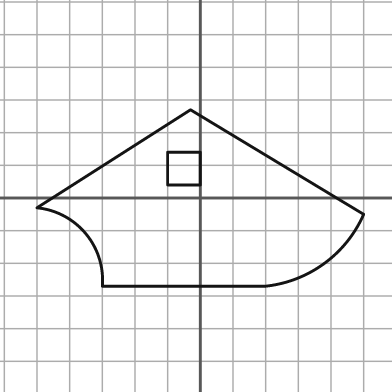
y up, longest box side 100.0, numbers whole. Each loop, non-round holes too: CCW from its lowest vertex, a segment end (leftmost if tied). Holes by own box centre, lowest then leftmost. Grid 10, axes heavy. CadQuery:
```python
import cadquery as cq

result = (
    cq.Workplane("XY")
    .moveTo(-30.0, -27.0)
    .lineTo(20.0, -27.0)
    .threePointArc((38.0, -20.0), (50.0, -5.0))
    .lineTo(-3.0, 27.0)
    .lineTo(-50.0, -3.0)
    .threePointArc((-35.0, -11.0), (-30.0, -27.0))
    .close()
    .moveTo(-10.0, 4.0)
    .lineTo(0.0, 4.0)
    .lineTo(0.0, 14.0)
    .lineTo(-10.0, 14.0)
    .close()
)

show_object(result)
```